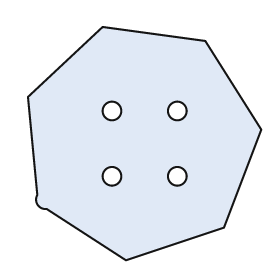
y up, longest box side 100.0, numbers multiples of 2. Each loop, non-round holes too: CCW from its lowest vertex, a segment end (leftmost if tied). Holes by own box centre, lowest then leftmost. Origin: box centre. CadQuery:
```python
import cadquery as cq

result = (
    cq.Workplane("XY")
    .moveTo(-8.0, -50.0)
    .lineTo(34.0, -36.0)
    .lineTo(50.0, 6.0)
    .lineTo(26.0, 44.0)
    .lineTo(-18.0, 50.0)
    .lineTo(-50.0, 20.0)
    .lineTo(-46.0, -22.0)
    .threePointArc((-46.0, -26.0), (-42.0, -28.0))
    .close()
    .moveTo(-14.0, -14.0)
    .circle(4.0)
    .moveTo(14.0, -14.0)
    .circle(4.0)
    .moveTo(-14.0, 14.0)
    .circle(4.0)
    .moveTo(14.0, 14.0)
    .circle(4.0)
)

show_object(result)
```